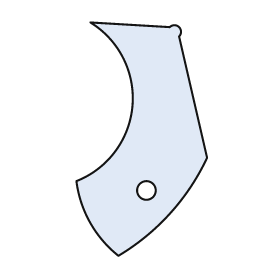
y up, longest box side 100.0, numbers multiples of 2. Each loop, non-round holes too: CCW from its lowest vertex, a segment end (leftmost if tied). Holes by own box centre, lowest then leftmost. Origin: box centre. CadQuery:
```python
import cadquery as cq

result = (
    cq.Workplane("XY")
    .moveTo(-10.0, -50.0)
    .threePointArc((12.0, -32.0), (28.0, -8.0))
    .lineTo(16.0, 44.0)
    .threePointArc((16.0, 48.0), (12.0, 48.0))
    .lineTo(-22.0, 50.0)
    .threePointArc((-4.0, 14.0), (-28.0, -18.0))
    .threePointArc((-22.0, -36.0), (-10.0, -50.0))
    .close()
    .moveTo(2.0, -22.0)
    .circle(4.0)
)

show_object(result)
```